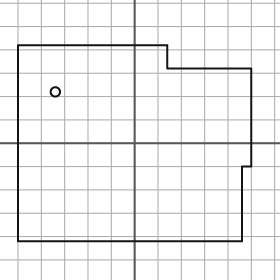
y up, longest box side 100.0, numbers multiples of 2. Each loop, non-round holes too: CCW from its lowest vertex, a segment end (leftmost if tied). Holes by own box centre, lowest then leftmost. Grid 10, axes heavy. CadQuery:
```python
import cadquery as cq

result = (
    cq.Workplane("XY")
    .moveTo(-50.0, -42.0)
    .lineTo(46.0, -42.0)
    .lineTo(46.0, -10.0)
    .lineTo(50.0, -10.0)
    .lineTo(50.0, 32.0)
    .lineTo(14.0, 32.0)
    .lineTo(14.0, 42.0)
    .lineTo(-50.0, 42.0)
    .close()
    .moveTo(-34.0, 22.0)
    .circle(2.0)
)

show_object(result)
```